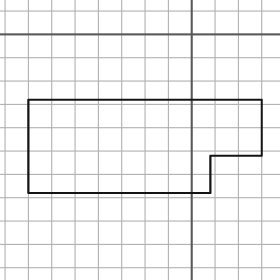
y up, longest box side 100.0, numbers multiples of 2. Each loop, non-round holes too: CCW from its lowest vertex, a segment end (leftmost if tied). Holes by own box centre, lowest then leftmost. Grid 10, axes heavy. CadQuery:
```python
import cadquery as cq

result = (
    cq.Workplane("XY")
    .moveTo(-70.0, -68.0)
    .lineTo(8.0, -68.0)
    .lineTo(8.0, -52.0)
    .lineTo(30.0, -52.0)
    .lineTo(30.0, -28.0)
    .lineTo(-70.0, -28.0)
    .close()
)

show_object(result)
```